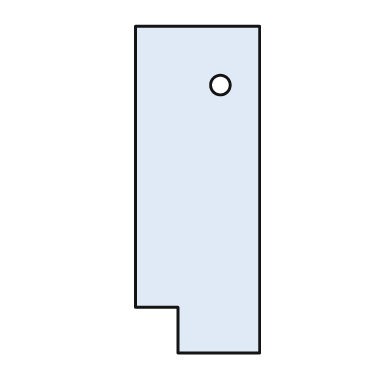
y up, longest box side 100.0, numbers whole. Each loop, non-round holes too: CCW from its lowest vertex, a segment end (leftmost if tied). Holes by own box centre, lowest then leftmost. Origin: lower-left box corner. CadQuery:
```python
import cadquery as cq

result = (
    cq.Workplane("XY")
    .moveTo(13.0, 0.0)
    .lineTo(38.0, 0.0)
    .lineTo(38.0, 100.0)
    .lineTo(0.0, 100.0)
    .lineTo(0.0, 14.0)
    .lineTo(13.0, 14.0)
    .close()
    .moveTo(26.0, 82.0)
    .circle(3.0)
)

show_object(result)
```